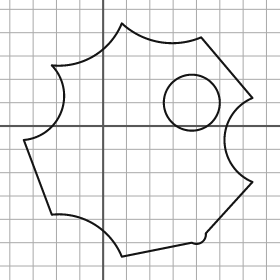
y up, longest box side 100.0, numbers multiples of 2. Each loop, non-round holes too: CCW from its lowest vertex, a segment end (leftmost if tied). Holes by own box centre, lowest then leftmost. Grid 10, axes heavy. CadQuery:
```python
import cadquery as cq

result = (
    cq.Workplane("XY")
    .moveTo(8.0, -56.0)
    .lineTo(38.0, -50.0)
    .threePointArc((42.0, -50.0), (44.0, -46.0))
    .lineTo(64.0, -24.0)
    .threePointArc((52.0, -6.0), (64.0, 12.0))
    .lineTo(42.0, 38.0)
    .threePointArc((24.0, 36.0), (8.0, 44.0))
    .threePointArc((-4.0, 30.0), (-22.0, 26.0))
    .threePointArc((-18.0, 6.0), (-34.0, -6.0))
    .lineTo(-22.0, -38.0)
    .threePointArc((-4.0, -42.0), (8.0, -56.0))
    .close()
    .moveTo(38.0, 10.0)
    .circle(12.0)
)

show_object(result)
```